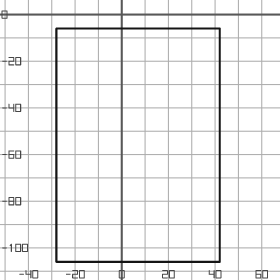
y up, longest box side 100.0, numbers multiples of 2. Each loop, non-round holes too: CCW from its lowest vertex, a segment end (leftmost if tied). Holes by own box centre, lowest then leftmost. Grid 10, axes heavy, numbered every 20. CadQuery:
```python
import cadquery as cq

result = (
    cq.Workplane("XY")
    .moveTo(-28.0, -106.0)
    .lineTo(42.0, -106.0)
    .lineTo(42.0, -6.0)
    .lineTo(-28.0, -6.0)
    .close()
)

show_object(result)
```